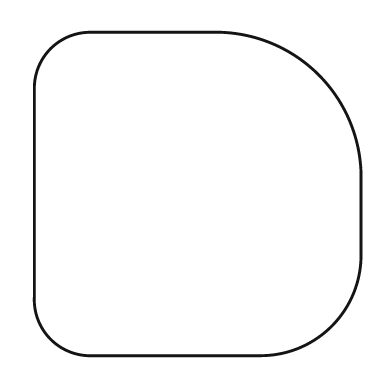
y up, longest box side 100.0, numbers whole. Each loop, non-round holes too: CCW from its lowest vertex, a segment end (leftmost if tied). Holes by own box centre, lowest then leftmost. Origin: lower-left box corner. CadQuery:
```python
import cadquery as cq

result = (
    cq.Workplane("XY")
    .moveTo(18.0, 0.0)
    .lineTo(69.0, 0.0)
    .threePointArc((91.0, 9.0), (100.0, 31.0))
    .lineTo(100.0, 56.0)
    .threePointArc((87.0, 86.0), (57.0, 99.0))
    .lineTo(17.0, 99.0)
    .threePointArc((5.0, 94.0), (0.0, 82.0))
    .lineTo(0.0, 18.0)
    .threePointArc((5.0, 5.0), (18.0, 0.0))
    .close()
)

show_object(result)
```